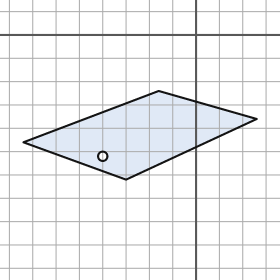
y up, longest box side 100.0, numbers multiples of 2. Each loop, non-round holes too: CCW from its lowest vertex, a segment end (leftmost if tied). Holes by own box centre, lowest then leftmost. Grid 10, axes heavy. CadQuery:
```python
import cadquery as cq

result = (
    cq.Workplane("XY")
    .moveTo(-30.0, -62.0)
    .lineTo(26.0, -36.0)
    .lineTo(-16.0, -24.0)
    .lineTo(-74.0, -46.0)
    .close()
    .moveTo(-40.0, -52.0)
    .circle(2.0)
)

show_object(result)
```